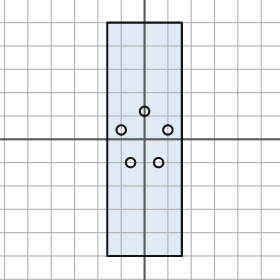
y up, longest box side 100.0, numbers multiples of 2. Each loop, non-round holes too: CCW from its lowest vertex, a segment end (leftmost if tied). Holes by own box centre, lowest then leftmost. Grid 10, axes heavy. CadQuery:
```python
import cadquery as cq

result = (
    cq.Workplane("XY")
    .moveTo(-16.0, -50.0)
    .lineTo(16.0, -50.0)
    .lineTo(16.0, 50.0)
    .lineTo(-16.0, 50.0)
    .close()
    .moveTo(-6.0, -10.0)
    .circle(2.0)
    .moveTo(6.0, -10.0)
    .circle(2.0)
    .moveTo(-10.0, 4.0)
    .circle(2.0)
    .moveTo(10.0, 4.0)
    .circle(2.0)
    .moveTo(0.0, 12.0)
    .circle(2.0)
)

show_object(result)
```